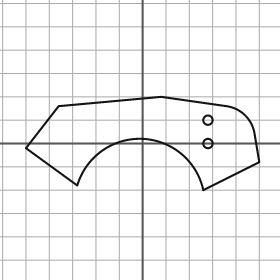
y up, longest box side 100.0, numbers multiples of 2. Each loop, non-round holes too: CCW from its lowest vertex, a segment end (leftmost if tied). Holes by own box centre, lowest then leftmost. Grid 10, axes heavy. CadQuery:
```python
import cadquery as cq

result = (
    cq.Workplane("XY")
    .moveTo(26.0, -20.0)
    .lineTo(50.0, -8.0)
    .lineTo(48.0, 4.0)
    .threePointArc((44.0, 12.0), (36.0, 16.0))
    .lineTo(8.0, 20.0)
    .lineTo(-36.0, 16.0)
    .lineTo(-50.0, -2.0)
    .lineTo(-28.0, -18.0)
    .threePointArc((0.0, 2.0), (26.0, -20.0))
    .close()
    .moveTo(28.0, 0.0)
    .circle(2.0)
    .moveTo(28.0, 10.0)
    .circle(2.0)
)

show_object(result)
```